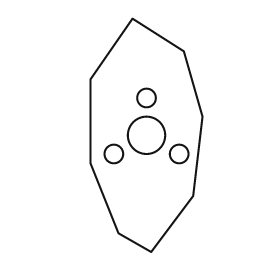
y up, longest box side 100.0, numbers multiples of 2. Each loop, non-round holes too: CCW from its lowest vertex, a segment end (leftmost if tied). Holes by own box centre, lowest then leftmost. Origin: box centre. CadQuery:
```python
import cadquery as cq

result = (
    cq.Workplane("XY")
    .moveTo(2.0, -50.0)
    .lineTo(20.0, -26.0)
    .lineTo(24.0, 8.0)
    .lineTo(16.0, 36.0)
    .lineTo(-6.0, 50.0)
    .lineTo(-24.0, 24.0)
    .lineTo(-24.0, -12.0)
    .lineTo(-12.0, -42.0)
    .close()
    .moveTo(-14.0, -8.0)
    .circle(4.0)
    .moveTo(14.0, -8.0)
    .circle(4.0)
    .moveTo(0.0, 0.0)
    .circle(8.0)
    .moveTo(0.0, 16.0)
    .circle(4.0)
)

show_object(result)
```